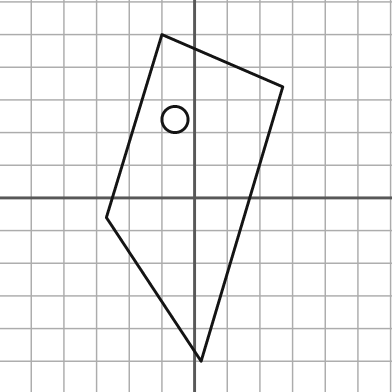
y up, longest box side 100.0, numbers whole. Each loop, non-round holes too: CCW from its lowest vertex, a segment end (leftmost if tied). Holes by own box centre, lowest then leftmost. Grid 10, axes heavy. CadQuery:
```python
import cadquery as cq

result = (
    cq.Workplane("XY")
    .moveTo(2.0, -50.0)
    .lineTo(27.0, 34.0)
    .lineTo(-10.0, 50.0)
    .lineTo(-27.0, -6.0)
    .close()
    .moveTo(-6.0, 24.0)
    .circle(4.0)
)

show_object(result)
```